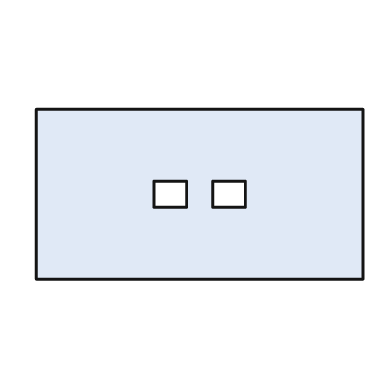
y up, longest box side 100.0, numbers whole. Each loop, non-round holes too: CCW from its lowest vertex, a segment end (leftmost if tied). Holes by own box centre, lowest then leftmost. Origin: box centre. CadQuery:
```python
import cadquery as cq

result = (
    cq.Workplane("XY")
    .moveTo(-50.0, -26.0)
    .lineTo(50.0, -26.0)
    .lineTo(50.0, 26.0)
    .lineTo(-50.0, 26.0)
    .close()
    .moveTo(-14.0, -4.0)
    .lineTo(-4.0, -4.0)
    .lineTo(-4.0, 4.0)
    .lineTo(-14.0, 4.0)
    .close()
    .moveTo(4.0, -4.0)
    .lineTo(14.0, -4.0)
    .lineTo(14.0, 4.0)
    .lineTo(4.0, 4.0)
    .close()
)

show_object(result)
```